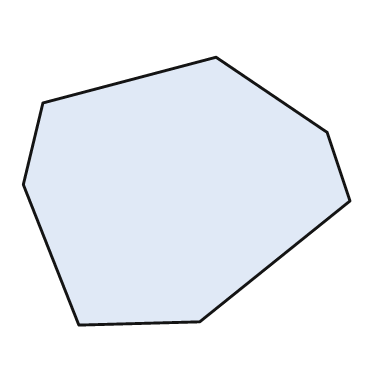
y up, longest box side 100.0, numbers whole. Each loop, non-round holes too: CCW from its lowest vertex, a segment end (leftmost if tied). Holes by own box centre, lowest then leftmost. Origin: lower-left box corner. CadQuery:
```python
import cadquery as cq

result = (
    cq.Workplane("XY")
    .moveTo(17.0, 0.0)
    .lineTo(54.0, 1.0)
    .lineTo(100.0, 38.0)
    .lineTo(93.0, 59.0)
    .lineTo(59.0, 82.0)
    .lineTo(6.0, 68.0)
    .lineTo(0.0, 43.0)
    .close()
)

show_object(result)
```